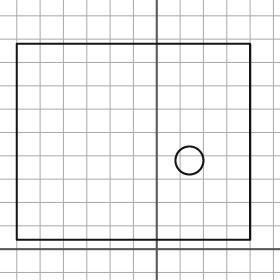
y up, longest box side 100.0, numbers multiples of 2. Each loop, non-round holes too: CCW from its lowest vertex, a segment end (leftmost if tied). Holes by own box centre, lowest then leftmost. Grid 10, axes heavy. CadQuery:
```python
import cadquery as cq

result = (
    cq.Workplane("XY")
    .moveTo(-60.0, 4.0)
    .lineTo(40.0, 4.0)
    .lineTo(40.0, 88.0)
    .lineTo(-60.0, 88.0)
    .close()
    .moveTo(14.0, 38.0)
    .circle(6.0)
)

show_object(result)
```